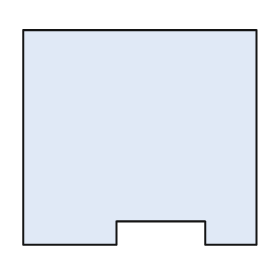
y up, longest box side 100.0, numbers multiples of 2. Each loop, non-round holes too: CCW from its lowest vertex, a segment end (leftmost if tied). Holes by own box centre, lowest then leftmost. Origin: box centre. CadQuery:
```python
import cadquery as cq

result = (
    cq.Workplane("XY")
    .moveTo(-50.0, -46.0)
    .lineTo(-10.0, -46.0)
    .lineTo(-10.0, -36.0)
    .lineTo(28.0, -36.0)
    .lineTo(28.0, -46.0)
    .lineTo(50.0, -46.0)
    .lineTo(50.0, 46.0)
    .lineTo(-50.0, 46.0)
    .close()
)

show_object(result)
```